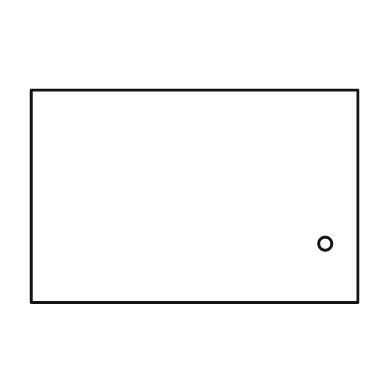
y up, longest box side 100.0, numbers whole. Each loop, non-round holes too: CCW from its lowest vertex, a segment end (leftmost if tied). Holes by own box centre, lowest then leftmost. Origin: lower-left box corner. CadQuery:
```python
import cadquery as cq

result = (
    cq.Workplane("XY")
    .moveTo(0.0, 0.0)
    .lineTo(100.0, 0.0)
    .lineTo(100.0, 65.0)
    .lineTo(0.0, 65.0)
    .close()
    .moveTo(90.0, 18.0)
    .circle(2.0)
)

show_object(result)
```